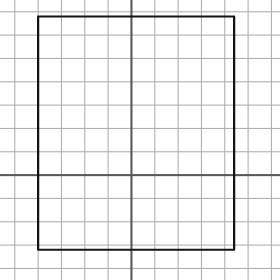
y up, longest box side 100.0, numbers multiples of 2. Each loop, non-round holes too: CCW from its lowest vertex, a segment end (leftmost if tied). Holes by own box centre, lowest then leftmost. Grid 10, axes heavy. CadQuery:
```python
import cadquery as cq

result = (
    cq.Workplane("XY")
    .moveTo(-40.0, -32.0)
    .lineTo(44.0, -32.0)
    .lineTo(44.0, 68.0)
    .lineTo(-40.0, 68.0)
    .close()
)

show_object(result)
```